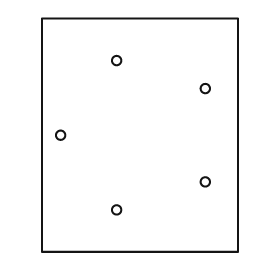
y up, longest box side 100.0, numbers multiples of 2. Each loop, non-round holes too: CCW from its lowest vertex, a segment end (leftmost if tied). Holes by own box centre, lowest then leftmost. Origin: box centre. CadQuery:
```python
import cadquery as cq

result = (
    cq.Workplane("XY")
    .moveTo(-42.0, -50.0)
    .lineTo(42.0, -50.0)
    .lineTo(42.0, 50.0)
    .lineTo(-42.0, 50.0)
    .close()
    .moveTo(-10.0, -32.0)
    .circle(2.0)
    .moveTo(28.0, -20.0)
    .circle(2.0)
    .moveTo(-34.0, 0.0)
    .circle(2.0)
    .moveTo(28.0, 20.0)
    .circle(2.0)
    .moveTo(-10.0, 32.0)
    .circle(2.0)
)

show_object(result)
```